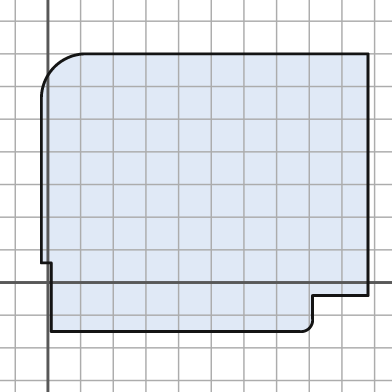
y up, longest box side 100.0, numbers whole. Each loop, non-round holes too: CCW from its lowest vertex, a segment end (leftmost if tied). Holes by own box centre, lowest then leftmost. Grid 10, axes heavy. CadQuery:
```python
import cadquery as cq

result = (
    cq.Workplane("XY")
    .moveTo(1.0, -15.0)
    .lineTo(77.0, -15.0)
    .threePointArc((80.0, -14.0), (81.0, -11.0))
    .lineTo(81.0, -4.0)
    .lineTo(98.0, -4.0)
    .lineTo(98.0, 70.0)
    .lineTo(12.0, 70.0)
    .threePointArc((2.0, 66.0), (-2.0, 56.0))
    .lineTo(-2.0, 6.0)
    .lineTo(1.0, 6.0)
    .close()
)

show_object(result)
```